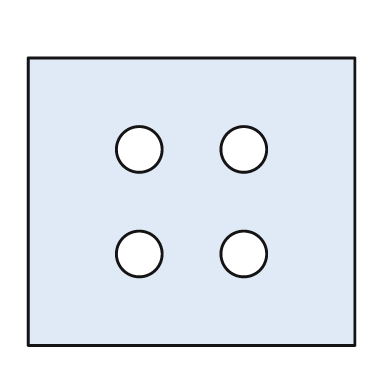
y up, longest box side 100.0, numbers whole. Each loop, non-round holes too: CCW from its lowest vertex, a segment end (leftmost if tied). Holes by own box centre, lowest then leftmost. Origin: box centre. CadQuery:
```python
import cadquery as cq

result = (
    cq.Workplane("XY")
    .moveTo(-50.0, -44.0)
    .lineTo(50.0, -44.0)
    .lineTo(50.0, 44.0)
    .lineTo(-50.0, 44.0)
    .close()
    .moveTo(-16.0, -16.0)
    .circle(7.0)
    .moveTo(16.0, -16.0)
    .circle(7.0)
    .moveTo(-16.0, 16.0)
    .circle(7.0)
    .moveTo(16.0, 16.0)
    .circle(7.0)
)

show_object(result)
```